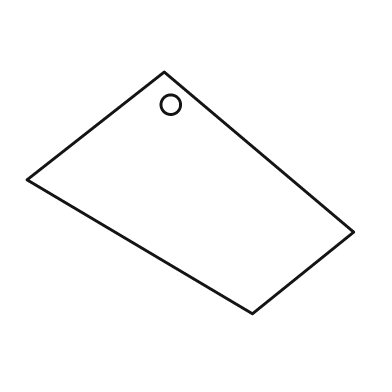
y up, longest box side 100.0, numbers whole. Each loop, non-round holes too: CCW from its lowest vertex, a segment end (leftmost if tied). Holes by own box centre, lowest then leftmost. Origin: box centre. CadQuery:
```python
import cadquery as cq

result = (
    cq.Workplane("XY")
    .moveTo(19.0, -37.0)
    .lineTo(50.0, -12.0)
    .lineTo(-8.0, 37.0)
    .lineTo(-50.0, 4.0)
    .close()
    .moveTo(-6.0, 27.0)
    .circle(3.0)
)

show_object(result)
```